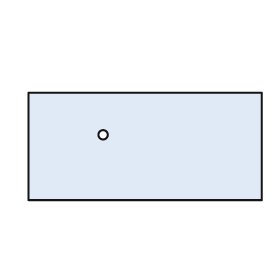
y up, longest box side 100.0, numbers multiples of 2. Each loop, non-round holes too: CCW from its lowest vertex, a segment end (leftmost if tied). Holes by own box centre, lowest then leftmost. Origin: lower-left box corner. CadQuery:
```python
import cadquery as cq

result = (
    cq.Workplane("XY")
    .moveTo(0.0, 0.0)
    .lineTo(100.0, 0.0)
    .lineTo(100.0, 46.0)
    .lineTo(0.0, 46.0)
    .close()
    .moveTo(32.0, 28.0)
    .circle(2.0)
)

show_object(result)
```